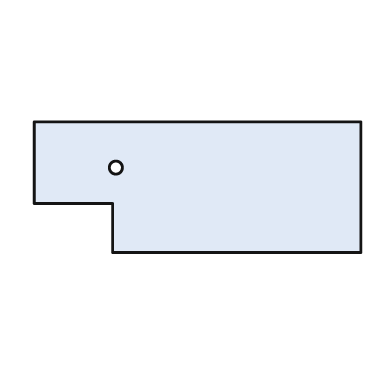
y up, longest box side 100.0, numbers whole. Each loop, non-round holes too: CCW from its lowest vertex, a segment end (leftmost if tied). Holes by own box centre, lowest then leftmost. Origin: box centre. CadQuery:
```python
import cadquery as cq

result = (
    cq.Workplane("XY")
    .moveTo(-26.0, -20.0)
    .lineTo(50.0, -20.0)
    .lineTo(50.0, 20.0)
    .lineTo(-50.0, 20.0)
    .lineTo(-50.0, -5.0)
    .lineTo(-26.0, -5.0)
    .close()
    .moveTo(-25.0, 6.0)
    .circle(2.0)
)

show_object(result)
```